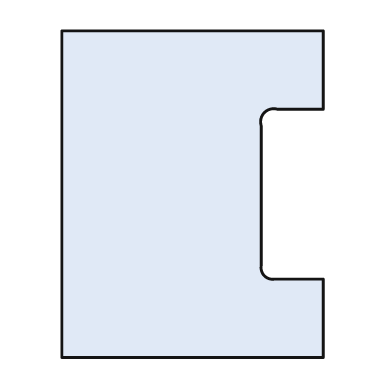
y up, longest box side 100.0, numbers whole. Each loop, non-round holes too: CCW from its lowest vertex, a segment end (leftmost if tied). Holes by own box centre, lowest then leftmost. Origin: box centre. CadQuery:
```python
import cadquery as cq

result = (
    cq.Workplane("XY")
    .moveTo(-40.0, -50.0)
    .lineTo(40.0, -50.0)
    .lineTo(40.0, -26.0)
    .lineTo(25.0, -26.0)
    .threePointArc((22.0, -25.0), (21.0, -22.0))
    .lineTo(21.0, 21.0)
    .threePointArc((22.0, 25.0), (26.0, 26.0))
    .lineTo(40.0, 26.0)
    .lineTo(40.0, 50.0)
    .lineTo(-40.0, 50.0)
    .close()
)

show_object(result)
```